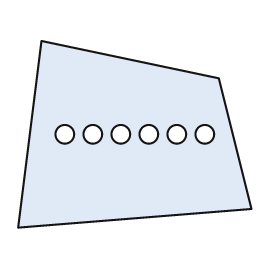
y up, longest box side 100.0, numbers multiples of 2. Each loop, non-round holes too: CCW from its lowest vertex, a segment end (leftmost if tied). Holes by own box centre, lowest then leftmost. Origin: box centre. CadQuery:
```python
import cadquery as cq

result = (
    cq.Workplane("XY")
    .moveTo(-50.0, -40.0)
    .lineTo(50.0, -32.0)
    .lineTo(36.0, 24.0)
    .lineTo(-40.0, 40.0)
    .close()
    .moveTo(-30.0, 0.0)
    .circle(4.0)
    .moveTo(-18.0, 0.0)
    .circle(4.0)
    .moveTo(-6.0, 0.0)
    .circle(4.0)
    .moveTo(6.0, 0.0)
    .circle(4.0)
    .moveTo(18.0, 0.0)
    .circle(4.0)
    .moveTo(30.0, 0.0)
    .circle(4.0)
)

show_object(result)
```